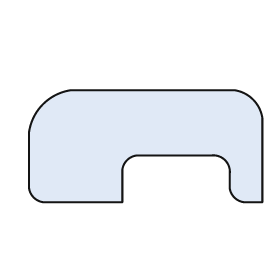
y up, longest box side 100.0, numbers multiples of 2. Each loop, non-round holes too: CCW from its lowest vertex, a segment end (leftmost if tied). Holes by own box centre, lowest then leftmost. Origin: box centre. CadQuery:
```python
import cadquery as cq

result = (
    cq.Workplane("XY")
    .moveTo(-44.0, -24.0)
    .lineTo(-10.0, -24.0)
    .lineTo(-10.0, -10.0)
    .threePointArc((-8.0, -6.0), (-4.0, -4.0))
    .lineTo(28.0, -4.0)
    .threePointArc((34.0, -6.0), (36.0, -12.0))
    .lineTo(36.0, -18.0)
    .threePointArc((38.0, -22.0), (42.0, -24.0))
    .lineTo(50.0, -24.0)
    .lineTo(50.0, 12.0)
    .threePointArc((46.0, 20.0), (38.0, 24.0))
    .lineTo(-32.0, 24.0)
    .threePointArc((-44.0, 18.0), (-50.0, 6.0))
    .lineTo(-50.0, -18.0)
    .threePointArc((-48.0, -22.0), (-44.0, -24.0))
    .close()
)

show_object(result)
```